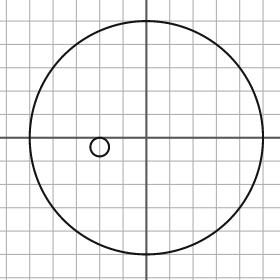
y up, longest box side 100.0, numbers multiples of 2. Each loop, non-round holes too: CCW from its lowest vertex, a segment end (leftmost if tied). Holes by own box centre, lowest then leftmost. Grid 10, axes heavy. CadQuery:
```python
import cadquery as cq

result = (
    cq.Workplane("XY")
    .moveTo(0.0, 0.0)
    .circle(50.0)
    .moveTo(-20.0, -4.0)
    .circle(4.0)
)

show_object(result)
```